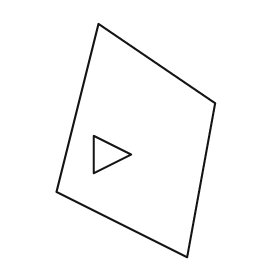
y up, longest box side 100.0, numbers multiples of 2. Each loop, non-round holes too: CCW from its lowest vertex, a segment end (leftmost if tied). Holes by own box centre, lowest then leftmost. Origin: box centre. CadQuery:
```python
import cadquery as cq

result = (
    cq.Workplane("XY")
    .moveTo(22.0, -50.0)
    .lineTo(34.0, 16.0)
    .lineTo(-16.0, 50.0)
    .lineTo(-34.0, -22.0)
    .close()
    .moveTo(-18.0, -14.0)
    .lineTo(-2.0, -6.0)
    .lineTo(-18.0, 2.0)
    .close()
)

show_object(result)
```